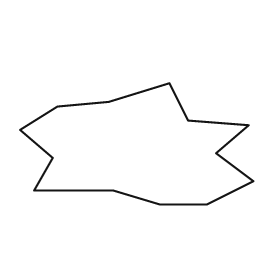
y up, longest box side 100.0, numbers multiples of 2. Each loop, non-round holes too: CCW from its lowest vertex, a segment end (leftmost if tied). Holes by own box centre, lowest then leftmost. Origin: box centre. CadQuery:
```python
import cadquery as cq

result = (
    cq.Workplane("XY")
    .moveTo(10.0, -26.0)
    .lineTo(30.0, -26.0)
    .lineTo(50.0, -16.0)
    .lineTo(34.0, -4.0)
    .lineTo(48.0, 8.0)
    .lineTo(22.0, 10.0)
    .lineTo(14.0, 26.0)
    .lineTo(-12.0, 18.0)
    .lineTo(-34.0, 16.0)
    .lineTo(-50.0, 6.0)
    .lineTo(-36.0, -6.0)
    .lineTo(-44.0, -20.0)
    .lineTo(-10.0, -20.0)
    .close()
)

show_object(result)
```